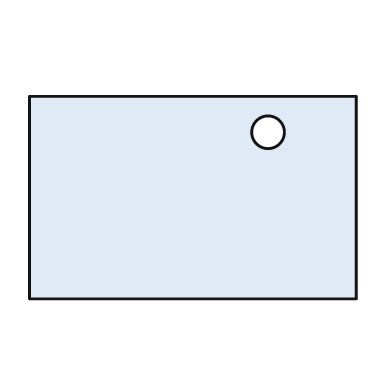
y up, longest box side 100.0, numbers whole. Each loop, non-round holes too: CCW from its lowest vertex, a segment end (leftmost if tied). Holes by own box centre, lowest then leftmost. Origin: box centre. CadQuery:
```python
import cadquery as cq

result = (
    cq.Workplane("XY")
    .moveTo(-50.0, -31.0)
    .lineTo(50.0, -31.0)
    .lineTo(50.0, 31.0)
    .lineTo(-50.0, 31.0)
    .close()
    .moveTo(23.0, 20.0)
    .circle(5.0)
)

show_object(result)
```